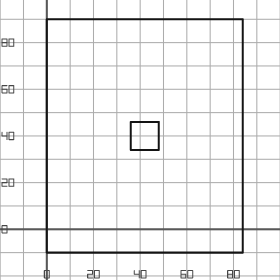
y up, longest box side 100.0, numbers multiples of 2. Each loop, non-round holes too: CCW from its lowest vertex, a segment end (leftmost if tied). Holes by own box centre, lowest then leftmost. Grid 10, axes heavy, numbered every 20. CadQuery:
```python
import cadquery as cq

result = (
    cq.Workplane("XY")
    .moveTo(0.0, -10.0)
    .lineTo(84.0, -10.0)
    .lineTo(84.0, 90.0)
    .lineTo(0.0, 90.0)
    .close()
    .moveTo(36.0, 34.0)
    .lineTo(48.0, 34.0)
    .lineTo(48.0, 46.0)
    .lineTo(36.0, 46.0)
    .close()
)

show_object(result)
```